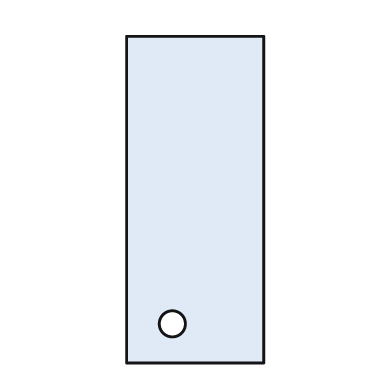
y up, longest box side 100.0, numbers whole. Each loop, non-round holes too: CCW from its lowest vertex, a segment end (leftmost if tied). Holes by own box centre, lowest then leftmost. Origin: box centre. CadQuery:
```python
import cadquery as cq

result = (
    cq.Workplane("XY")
    .moveTo(-21.0, -50.0)
    .lineTo(21.0, -50.0)
    .lineTo(21.0, 50.0)
    .lineTo(-21.0, 50.0)
    .close()
    .moveTo(-7.0, -38.0)
    .circle(4.0)
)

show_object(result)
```